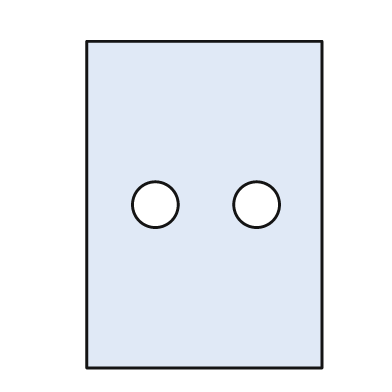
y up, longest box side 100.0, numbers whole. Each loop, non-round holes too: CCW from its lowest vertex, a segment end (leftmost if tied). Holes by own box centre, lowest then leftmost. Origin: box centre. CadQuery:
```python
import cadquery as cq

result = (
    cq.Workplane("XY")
    .moveTo(-36.0, -50.0)
    .lineTo(36.0, -50.0)
    .lineTo(36.0, 50.0)
    .lineTo(-36.0, 50.0)
    .close()
    .moveTo(-15.0, 0.0)
    .circle(7.0)
    .moveTo(16.0, 0.0)
    .circle(7.0)
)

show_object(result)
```